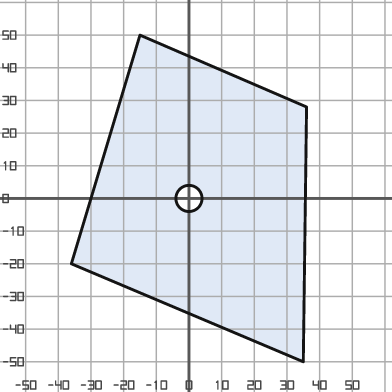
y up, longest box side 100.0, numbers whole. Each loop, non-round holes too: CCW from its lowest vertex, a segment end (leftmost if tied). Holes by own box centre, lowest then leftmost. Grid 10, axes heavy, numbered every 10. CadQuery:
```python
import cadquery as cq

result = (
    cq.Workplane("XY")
    .moveTo(35.0, -50.0)
    .lineTo(36.0, 28.0)
    .lineTo(-15.0, 50.0)
    .lineTo(-36.0, -20.0)
    .close()
    .moveTo(0.0, 0.0)
    .circle(4.0)
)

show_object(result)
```